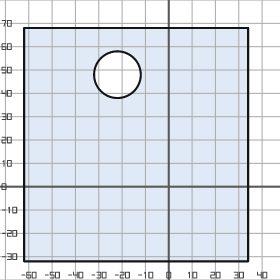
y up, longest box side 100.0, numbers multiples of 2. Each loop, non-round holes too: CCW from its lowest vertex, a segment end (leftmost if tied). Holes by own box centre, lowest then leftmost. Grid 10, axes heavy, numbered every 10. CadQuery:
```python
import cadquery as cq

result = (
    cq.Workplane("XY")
    .moveTo(-62.0, -32.0)
    .lineTo(34.0, -32.0)
    .lineTo(34.0, 68.0)
    .lineTo(-62.0, 68.0)
    .close()
    .moveTo(-22.0, 48.0)
    .circle(10.0)
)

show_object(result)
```